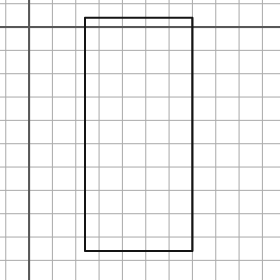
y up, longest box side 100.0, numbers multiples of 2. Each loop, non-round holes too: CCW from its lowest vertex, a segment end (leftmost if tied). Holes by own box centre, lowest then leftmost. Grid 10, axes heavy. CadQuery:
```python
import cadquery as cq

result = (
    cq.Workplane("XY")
    .moveTo(24.0, -96.0)
    .lineTo(70.0, -96.0)
    .lineTo(70.0, 4.0)
    .lineTo(24.0, 4.0)
    .close()
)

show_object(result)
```